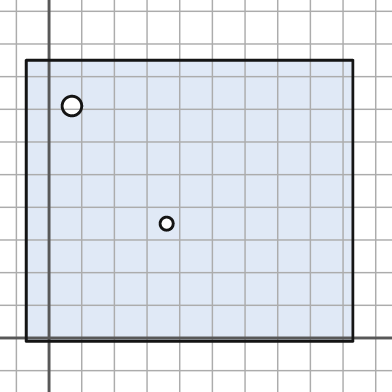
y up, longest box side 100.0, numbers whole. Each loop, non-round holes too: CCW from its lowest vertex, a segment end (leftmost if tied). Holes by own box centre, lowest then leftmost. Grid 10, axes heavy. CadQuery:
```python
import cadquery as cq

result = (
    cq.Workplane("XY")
    .moveTo(-7.0, -1.0)
    .lineTo(93.0, -1.0)
    .lineTo(93.0, 85.0)
    .lineTo(-7.0, 85.0)
    .close()
    .moveTo(36.0, 35.0)
    .circle(2.0)
    .moveTo(7.0, 71.0)
    .circle(3.0)
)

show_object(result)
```